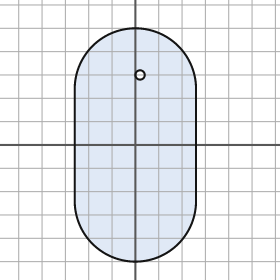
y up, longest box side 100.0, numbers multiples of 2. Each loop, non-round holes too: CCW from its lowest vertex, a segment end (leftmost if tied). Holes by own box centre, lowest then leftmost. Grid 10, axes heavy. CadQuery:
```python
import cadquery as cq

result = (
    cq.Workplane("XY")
    .moveTo(-26.0, -24.0)
    .threePointArc((0.0, -50.0), (26.0, -24.0))
    .lineTo(26.0, 24.0)
    .threePointArc((0.0, 50.0), (-26.0, 24.0))
    .close()
    .moveTo(2.0, 30.0)
    .circle(2.0)
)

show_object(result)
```